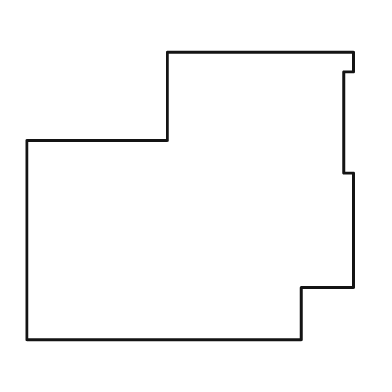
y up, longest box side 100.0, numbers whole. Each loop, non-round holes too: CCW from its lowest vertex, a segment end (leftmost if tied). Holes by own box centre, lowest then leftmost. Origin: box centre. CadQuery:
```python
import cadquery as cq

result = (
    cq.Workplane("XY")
    .moveTo(-50.0, -44.0)
    .lineTo(34.0, -44.0)
    .lineTo(34.0, -28.0)
    .lineTo(50.0, -28.0)
    .lineTo(50.0, 7.0)
    .lineTo(47.0, 7.0)
    .lineTo(47.0, 38.0)
    .lineTo(50.0, 38.0)
    .lineTo(50.0, 44.0)
    .lineTo(-7.0, 44.0)
    .lineTo(-7.0, 17.0)
    .lineTo(-50.0, 17.0)
    .close()
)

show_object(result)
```